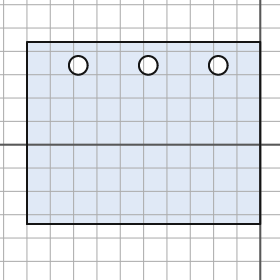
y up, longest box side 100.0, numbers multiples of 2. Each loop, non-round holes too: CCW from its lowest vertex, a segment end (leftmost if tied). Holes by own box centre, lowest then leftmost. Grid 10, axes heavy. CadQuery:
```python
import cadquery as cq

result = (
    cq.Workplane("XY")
    .moveTo(-100.0, -34.0)
    .lineTo(0.0, -34.0)
    .lineTo(0.0, 44.0)
    .lineTo(-100.0, 44.0)
    .close()
    .moveTo(-78.0, 34.0)
    .circle(4.0)
    .moveTo(-48.0, 34.0)
    .circle(4.0)
    .moveTo(-18.0, 34.0)
    .circle(4.0)
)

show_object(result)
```